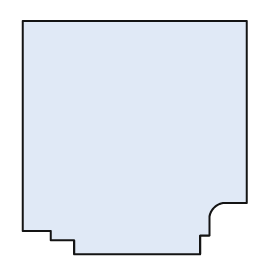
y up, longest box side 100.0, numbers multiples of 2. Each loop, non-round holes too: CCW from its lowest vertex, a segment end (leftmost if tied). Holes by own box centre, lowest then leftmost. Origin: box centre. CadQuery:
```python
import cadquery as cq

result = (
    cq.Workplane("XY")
    .moveTo(-26.0, -50.0)
    .lineTo(28.0, -50.0)
    .lineTo(28.0, -42.0)
    .lineTo(32.0, -42.0)
    .lineTo(32.0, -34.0)
    .threePointArc((34.0, -30.0), (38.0, -28.0))
    .lineTo(48.0, -28.0)
    .lineTo(48.0, 50.0)
    .lineTo(-48.0, 50.0)
    .lineTo(-48.0, -40.0)
    .lineTo(-36.0, -40.0)
    .lineTo(-36.0, -44.0)
    .lineTo(-26.0, -44.0)
    .close()
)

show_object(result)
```